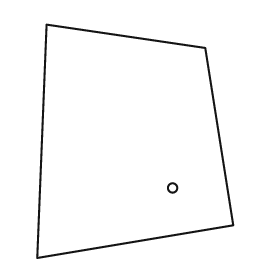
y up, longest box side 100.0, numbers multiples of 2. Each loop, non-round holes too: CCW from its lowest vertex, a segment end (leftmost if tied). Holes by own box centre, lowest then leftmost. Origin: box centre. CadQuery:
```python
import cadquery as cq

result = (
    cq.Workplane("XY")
    .moveTo(-42.0, -50.0)
    .lineTo(42.0, -36.0)
    .lineTo(30.0, 40.0)
    .lineTo(-38.0, 50.0)
    .close()
    .moveTo(16.0, -20.0)
    .circle(2.0)
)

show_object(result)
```